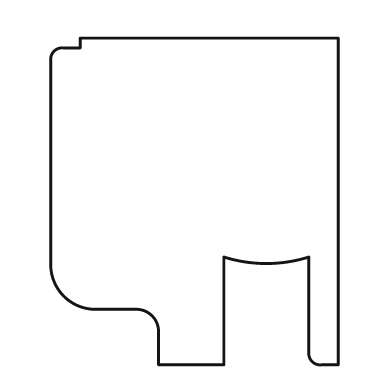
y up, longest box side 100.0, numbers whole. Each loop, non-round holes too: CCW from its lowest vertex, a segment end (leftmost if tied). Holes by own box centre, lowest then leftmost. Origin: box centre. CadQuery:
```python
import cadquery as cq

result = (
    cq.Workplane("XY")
    .moveTo(-11.0, -50.0)
    .lineTo(9.0, -50.0)
    .lineTo(9.0, -17.0)
    .threePointArc((22.0, -19.0), (35.0, -17.0))
    .lineTo(35.0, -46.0)
    .threePointArc((36.0, -49.0), (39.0, -50.0))
    .lineTo(44.0, -50.0)
    .lineTo(44.0, 50.0)
    .lineTo(-35.0, 50.0)
    .lineTo(-35.0, 47.0)
    .lineTo(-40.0, 47.0)
    .threePointArc((-43.0, 46.0), (-44.0, 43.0))
    .lineTo(-44.0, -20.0)
    .threePointArc((-40.0, -29.0), (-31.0, -33.0))
    .lineTo(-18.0, -33.0)
    .threePointArc((-13.0, -35.0), (-11.0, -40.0))
    .close()
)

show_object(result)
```